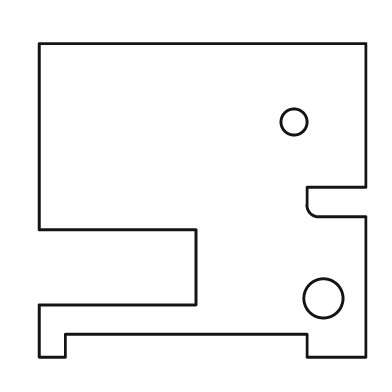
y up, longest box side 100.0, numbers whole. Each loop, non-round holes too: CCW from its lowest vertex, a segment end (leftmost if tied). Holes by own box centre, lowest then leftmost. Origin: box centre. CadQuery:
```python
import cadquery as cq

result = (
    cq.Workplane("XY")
    .moveTo(-50.0, -48.0)
    .lineTo(-42.0, -48.0)
    .lineTo(-42.0, -41.0)
    .lineTo(32.0, -41.0)
    .lineTo(32.0, -48.0)
    .lineTo(50.0, -48.0)
    .lineTo(50.0, -5.0)
    .lineTo(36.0, -5.0)
    .threePointArc((33.0, -4.0), (32.0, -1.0))
    .lineTo(32.0, 4.0)
    .lineTo(50.0, 4.0)
    .lineTo(50.0, 48.0)
    .lineTo(-50.0, 48.0)
    .lineTo(-50.0, -9.0)
    .lineTo(-2.0, -9.0)
    .lineTo(-2.0, -32.0)
    .lineTo(-50.0, -32.0)
    .close()
    .moveTo(37.0, -30.0)
    .circle(6.0)
    .moveTo(28.0, 24.0)
    .circle(4.0)
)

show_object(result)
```